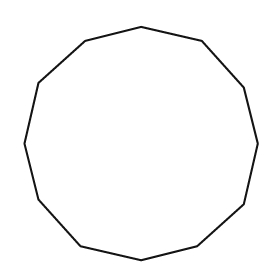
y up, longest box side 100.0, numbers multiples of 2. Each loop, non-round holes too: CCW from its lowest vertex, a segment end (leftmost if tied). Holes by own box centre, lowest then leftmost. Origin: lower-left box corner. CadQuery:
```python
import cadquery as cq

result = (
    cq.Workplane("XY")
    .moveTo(50.0, 0.0)
    .lineTo(74.0, 6.0)
    .lineTo(94.0, 24.0)
    .lineTo(100.0, 50.0)
    .lineTo(94.0, 74.0)
    .lineTo(76.0, 94.0)
    .lineTo(50.0, 100.0)
    .lineTo(26.0, 94.0)
    .lineTo(6.0, 76.0)
    .lineTo(0.0, 50.0)
    .lineTo(6.0, 26.0)
    .lineTo(24.0, 6.0)
    .close()
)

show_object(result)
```